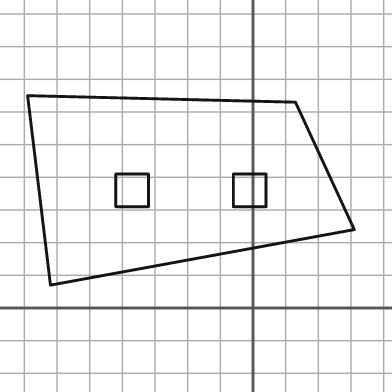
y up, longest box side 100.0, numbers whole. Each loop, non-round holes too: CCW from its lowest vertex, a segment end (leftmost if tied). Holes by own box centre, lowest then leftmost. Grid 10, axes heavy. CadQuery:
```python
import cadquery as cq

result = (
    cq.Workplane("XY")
    .moveTo(-62.0, 7.0)
    .lineTo(31.0, 24.0)
    .lineTo(13.0, 63.0)
    .lineTo(-69.0, 65.0)
    .close()
    .moveTo(-42.0, 31.0)
    .lineTo(-32.0, 31.0)
    .lineTo(-32.0, 41.0)
    .lineTo(-42.0, 41.0)
    .close()
    .moveTo(-6.0, 31.0)
    .lineTo(4.0, 31.0)
    .lineTo(4.0, 41.0)
    .lineTo(-6.0, 41.0)
    .close()
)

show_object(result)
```